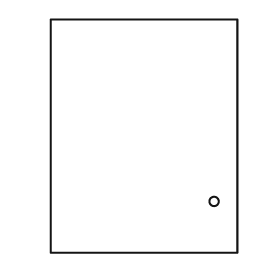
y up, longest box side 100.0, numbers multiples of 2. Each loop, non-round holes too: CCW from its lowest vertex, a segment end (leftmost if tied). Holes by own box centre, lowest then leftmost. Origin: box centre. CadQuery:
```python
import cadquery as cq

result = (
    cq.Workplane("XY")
    .moveTo(-40.0, -50.0)
    .lineTo(40.0, -50.0)
    .lineTo(40.0, 50.0)
    .lineTo(-40.0, 50.0)
    .close()
    .moveTo(30.0, -28.0)
    .circle(2.0)
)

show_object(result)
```